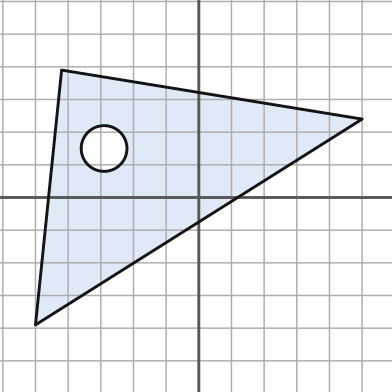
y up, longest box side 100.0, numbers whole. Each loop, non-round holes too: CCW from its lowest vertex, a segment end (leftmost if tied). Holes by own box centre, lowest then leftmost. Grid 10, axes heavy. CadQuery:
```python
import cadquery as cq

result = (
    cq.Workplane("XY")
    .moveTo(-50.0, -39.0)
    .lineTo(50.0, 24.0)
    .lineTo(-42.0, 39.0)
    .close()
    .moveTo(-29.0, 15.0)
    .circle(7.0)
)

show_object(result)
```